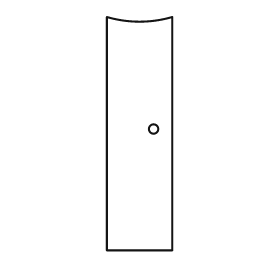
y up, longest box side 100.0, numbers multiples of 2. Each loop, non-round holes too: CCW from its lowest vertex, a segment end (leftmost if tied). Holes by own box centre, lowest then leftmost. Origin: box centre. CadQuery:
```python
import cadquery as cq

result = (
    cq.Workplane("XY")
    .moveTo(-14.0, -50.0)
    .lineTo(14.0, -50.0)
    .lineTo(14.0, 50.0)
    .threePointArc((0.0, 48.0), (-14.0, 50.0))
    .close()
    .moveTo(6.0, 2.0)
    .circle(2.0)
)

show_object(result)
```